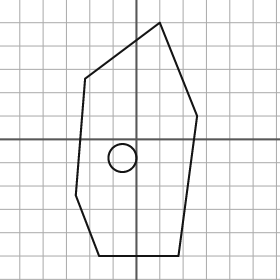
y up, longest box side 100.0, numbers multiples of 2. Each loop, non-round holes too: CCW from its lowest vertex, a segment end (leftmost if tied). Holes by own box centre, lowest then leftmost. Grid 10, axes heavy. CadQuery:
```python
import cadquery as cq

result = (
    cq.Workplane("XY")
    .moveTo(-16.0, -50.0)
    .lineTo(18.0, -50.0)
    .lineTo(26.0, 10.0)
    .lineTo(10.0, 50.0)
    .lineTo(-22.0, 26.0)
    .lineTo(-26.0, -24.0)
    .close()
    .moveTo(-6.0, -8.0)
    .circle(6.0)
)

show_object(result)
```